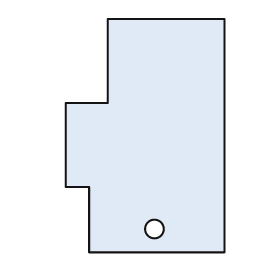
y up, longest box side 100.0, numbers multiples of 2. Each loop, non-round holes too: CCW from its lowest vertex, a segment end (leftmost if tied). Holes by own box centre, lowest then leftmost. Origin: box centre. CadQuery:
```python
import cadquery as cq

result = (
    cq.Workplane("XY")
    .moveTo(-24.0, -50.0)
    .lineTo(34.0, -50.0)
    .lineTo(34.0, 50.0)
    .lineTo(-16.0, 50.0)
    .lineTo(-16.0, 14.0)
    .lineTo(-34.0, 14.0)
    .lineTo(-34.0, -22.0)
    .lineTo(-24.0, -22.0)
    .close()
    .moveTo(4.0, -40.0)
    .circle(4.0)
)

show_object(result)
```